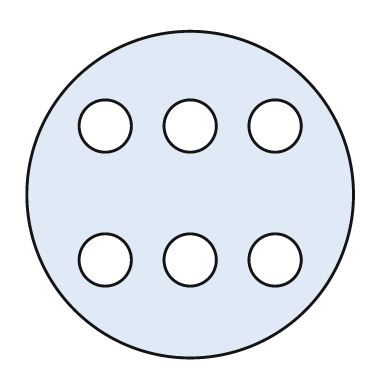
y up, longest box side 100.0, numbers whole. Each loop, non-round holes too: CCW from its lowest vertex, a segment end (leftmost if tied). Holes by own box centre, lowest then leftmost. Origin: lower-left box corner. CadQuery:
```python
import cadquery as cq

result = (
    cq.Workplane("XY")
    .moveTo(50.0, 50.0)
    .circle(50.0)
    .moveTo(24.0, 30.0)
    .circle(8.0)
    .moveTo(50.0, 30.0)
    .circle(8.0)
    .moveTo(76.0, 30.0)
    .circle(8.0)
    .moveTo(24.0, 71.0)
    .circle(8.0)
    .moveTo(50.0, 71.0)
    .circle(8.0)
    .moveTo(76.0, 71.0)
    .circle(8.0)
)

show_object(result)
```